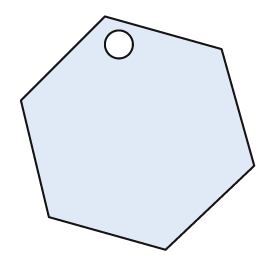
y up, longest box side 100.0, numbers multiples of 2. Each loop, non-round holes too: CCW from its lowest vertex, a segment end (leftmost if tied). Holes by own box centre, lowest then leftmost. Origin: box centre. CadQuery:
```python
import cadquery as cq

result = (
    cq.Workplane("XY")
    .moveTo(12.0, -50.0)
    .lineTo(50.0, -14.0)
    .lineTo(36.0, 36.0)
    .lineTo(-14.0, 50.0)
    .lineTo(-50.0, 14.0)
    .lineTo(-38.0, -36.0)
    .close()
    .moveTo(-8.0, 38.0)
    .circle(6.0)
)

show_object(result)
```